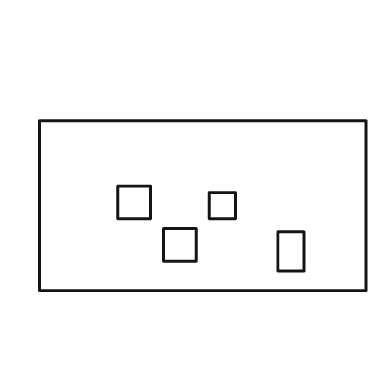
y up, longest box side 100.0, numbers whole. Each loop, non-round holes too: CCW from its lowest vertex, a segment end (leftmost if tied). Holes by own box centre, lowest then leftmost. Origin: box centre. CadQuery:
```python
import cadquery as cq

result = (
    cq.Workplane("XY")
    .moveTo(-50.0, -26.0)
    .lineTo(50.0, -26.0)
    .lineTo(50.0, 26.0)
    .lineTo(-50.0, 26.0)
    .close()
    .moveTo(23.0, -20.0)
    .lineTo(31.0, -20.0)
    .lineTo(31.0, -8.0)
    .lineTo(23.0, -8.0)
    .close()
    .moveTo(-12.0, -17.0)
    .lineTo(-2.0, -17.0)
    .lineTo(-2.0, -7.0)
    .lineTo(-12.0, -7.0)
    .close()
    .moveTo(2.0, -4.0)
    .lineTo(10.0, -4.0)
    .lineTo(10.0, 4.0)
    .lineTo(2.0, 4.0)
    .close()
    .moveTo(-26.0, -4.0)
    .lineTo(-16.0, -4.0)
    .lineTo(-16.0, 6.0)
    .lineTo(-26.0, 6.0)
    .close()
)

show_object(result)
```